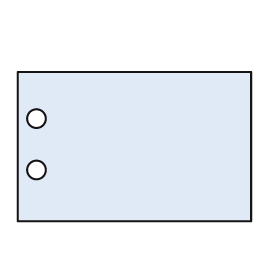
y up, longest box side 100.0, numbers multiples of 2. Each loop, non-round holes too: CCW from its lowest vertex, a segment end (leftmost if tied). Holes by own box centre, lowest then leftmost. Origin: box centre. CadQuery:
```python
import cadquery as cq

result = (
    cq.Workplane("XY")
    .moveTo(-50.0, -32.0)
    .lineTo(50.0, -32.0)
    .lineTo(50.0, 32.0)
    .lineTo(-50.0, 32.0)
    .close()
    .moveTo(-42.0, -10.0)
    .circle(4.0)
    .moveTo(-42.0, 12.0)
    .circle(4.0)
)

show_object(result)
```